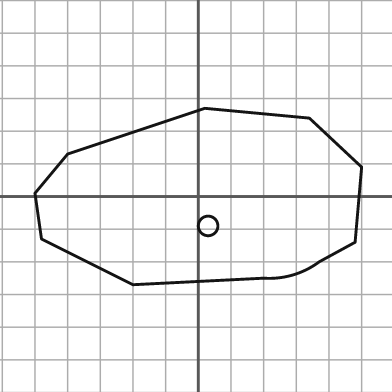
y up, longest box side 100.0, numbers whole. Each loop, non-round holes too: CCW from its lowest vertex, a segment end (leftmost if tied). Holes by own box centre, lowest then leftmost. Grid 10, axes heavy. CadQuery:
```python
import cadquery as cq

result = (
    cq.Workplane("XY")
    .moveTo(-20.0, -27.0)
    .lineTo(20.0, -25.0)
    .threePointArc((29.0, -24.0), (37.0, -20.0))
    .lineTo(48.0, -14.0)
    .lineTo(50.0, 9.0)
    .lineTo(34.0, 24.0)
    .lineTo(2.0, 27.0)
    .lineTo(-40.0, 13.0)
    .lineTo(-50.0, 1.0)
    .lineTo(-48.0, -13.0)
    .close()
    .moveTo(3.0, -9.0)
    .circle(3.0)
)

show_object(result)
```